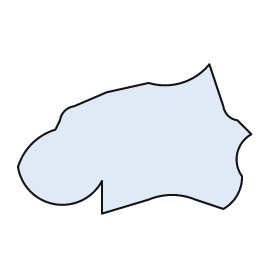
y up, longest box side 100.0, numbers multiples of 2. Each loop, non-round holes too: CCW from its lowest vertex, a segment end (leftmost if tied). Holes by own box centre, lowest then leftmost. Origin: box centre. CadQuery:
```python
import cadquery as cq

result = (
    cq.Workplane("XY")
    .moveTo(-14.0, -32.0)
    .lineTo(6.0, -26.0)
    .threePointArc((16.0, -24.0), (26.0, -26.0))
    .lineTo(38.0, -30.0)
    .threePointArc((44.0, -24.0), (46.0, -16.0))
    .threePointArc((44.0, -6.0), (50.0, 2.0))
    .lineTo(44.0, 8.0)
    .threePointArc((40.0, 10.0), (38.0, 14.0))
    .lineTo(32.0, 32.0)
    .threePointArc((20.0, 24.0), (6.0, 24.0))
    .lineTo(-12.0, 20.0)
    .lineTo(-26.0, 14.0)
    .threePointArc((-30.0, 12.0), (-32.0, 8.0))
    .lineTo(-34.0, 4.0)
    .threePointArc((-44.0, -2.0), (-50.0, -12.0))
    .threePointArc((-34.0, -28.0), (-14.0, -18.0))
    .close()
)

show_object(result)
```